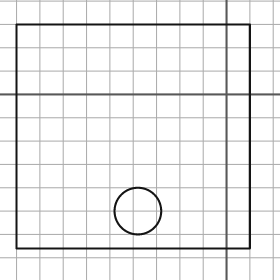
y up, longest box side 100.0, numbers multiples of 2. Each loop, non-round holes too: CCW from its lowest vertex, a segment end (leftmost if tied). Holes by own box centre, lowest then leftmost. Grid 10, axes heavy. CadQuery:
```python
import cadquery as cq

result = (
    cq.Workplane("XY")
    .moveTo(-90.0, -66.0)
    .lineTo(10.0, -66.0)
    .lineTo(10.0, 30.0)
    .lineTo(-90.0, 30.0)
    .close()
    .moveTo(-38.0, -50.0)
    .circle(10.0)
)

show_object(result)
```